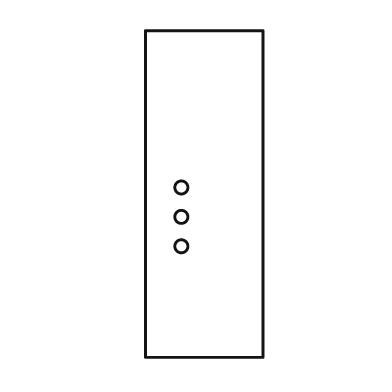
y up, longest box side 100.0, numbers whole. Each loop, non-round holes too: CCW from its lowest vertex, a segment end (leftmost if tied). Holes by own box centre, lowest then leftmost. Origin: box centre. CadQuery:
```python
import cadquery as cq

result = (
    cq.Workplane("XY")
    .moveTo(-18.0, -50.0)
    .lineTo(18.0, -50.0)
    .lineTo(18.0, 50.0)
    .lineTo(-18.0, 50.0)
    .close()
    .moveTo(-7.0, -16.0)
    .circle(2.0)
    .moveTo(-7.0, -7.0)
    .circle(2.0)
    .moveTo(-7.0, 2.0)
    .circle(2.0)
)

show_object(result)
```